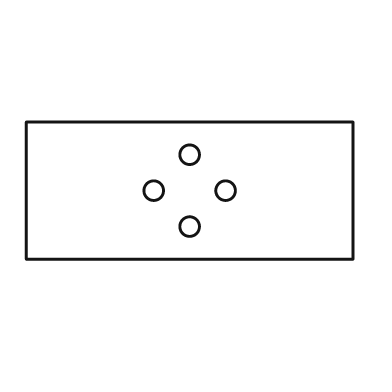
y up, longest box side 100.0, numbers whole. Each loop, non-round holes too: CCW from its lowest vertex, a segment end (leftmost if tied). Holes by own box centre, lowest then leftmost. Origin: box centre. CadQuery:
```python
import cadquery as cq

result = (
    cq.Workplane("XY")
    .moveTo(-50.0, -21.0)
    .lineTo(50.0, -21.0)
    .lineTo(50.0, 21.0)
    .lineTo(-50.0, 21.0)
    .close()
    .moveTo(0.0, -11.0)
    .circle(3.0)
    .moveTo(-11.0, 0.0)
    .circle(3.0)
    .moveTo(11.0, 0.0)
    .circle(3.0)
    .moveTo(0.0, 11.0)
    .circle(3.0)
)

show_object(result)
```